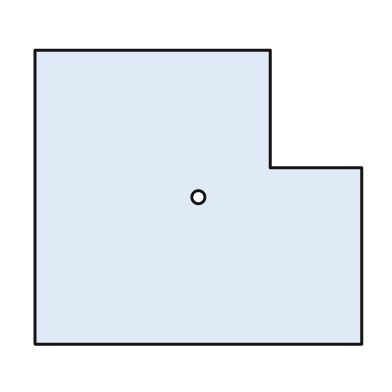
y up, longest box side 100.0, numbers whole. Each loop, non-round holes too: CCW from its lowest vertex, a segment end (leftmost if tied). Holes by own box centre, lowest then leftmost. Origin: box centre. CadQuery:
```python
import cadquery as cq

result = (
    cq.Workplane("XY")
    .moveTo(-50.0, -45.0)
    .lineTo(50.0, -45.0)
    .lineTo(50.0, 9.0)
    .lineTo(22.0, 9.0)
    .lineTo(22.0, 45.0)
    .lineTo(-50.0, 45.0)
    .close()
    .moveTo(0.0, 0.0)
    .circle(2.0)
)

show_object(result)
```